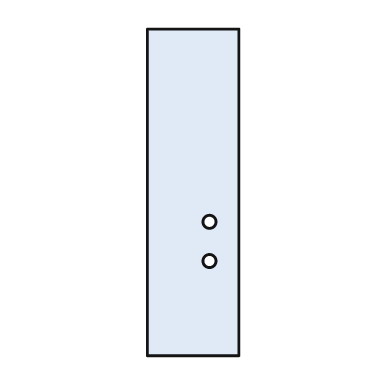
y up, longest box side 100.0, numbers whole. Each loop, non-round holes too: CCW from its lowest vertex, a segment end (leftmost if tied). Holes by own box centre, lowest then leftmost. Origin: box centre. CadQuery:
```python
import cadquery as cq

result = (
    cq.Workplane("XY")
    .moveTo(-14.0, -50.0)
    .lineTo(14.0, -50.0)
    .lineTo(14.0, 50.0)
    .lineTo(-14.0, 50.0)
    .close()
    .moveTo(5.0, -21.0)
    .circle(2.0)
    .moveTo(5.0, -9.0)
    .circle(2.0)
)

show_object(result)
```